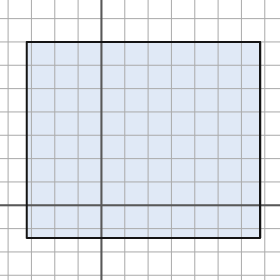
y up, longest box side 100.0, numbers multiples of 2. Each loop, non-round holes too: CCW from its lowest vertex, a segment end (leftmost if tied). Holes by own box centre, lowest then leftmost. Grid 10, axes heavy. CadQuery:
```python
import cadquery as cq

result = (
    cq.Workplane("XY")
    .moveTo(-32.0, -14.0)
    .lineTo(68.0, -14.0)
    .lineTo(68.0, 70.0)
    .lineTo(-32.0, 70.0)
    .close()
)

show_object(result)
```